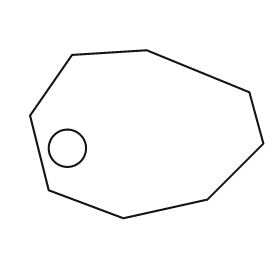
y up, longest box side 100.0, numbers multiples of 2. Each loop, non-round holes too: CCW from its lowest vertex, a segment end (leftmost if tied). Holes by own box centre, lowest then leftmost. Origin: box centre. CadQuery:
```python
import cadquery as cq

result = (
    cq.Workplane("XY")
    .moveTo(-10.0, -36.0)
    .lineTo(26.0, -28.0)
    .lineTo(50.0, -4.0)
    .lineTo(44.0, 18.0)
    .lineTo(0.0, 36.0)
    .lineTo(-32.0, 34.0)
    .lineTo(-50.0, 8.0)
    .lineTo(-42.0, -24.0)
    .close()
    .moveTo(-34.0, -6.0)
    .circle(8.0)
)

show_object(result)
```